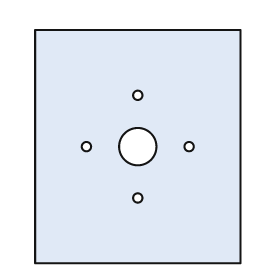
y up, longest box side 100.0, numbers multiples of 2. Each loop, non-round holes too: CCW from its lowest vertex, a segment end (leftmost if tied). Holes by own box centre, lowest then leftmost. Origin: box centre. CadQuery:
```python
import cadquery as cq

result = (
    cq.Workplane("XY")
    .moveTo(-44.0, -50.0)
    .lineTo(44.0, -50.0)
    .lineTo(44.0, 50.0)
    .lineTo(-44.0, 50.0)
    .close()
    .moveTo(0.0, -22.0)
    .circle(2.0)
    .moveTo(-22.0, 0.0)
    .circle(2.0)
    .moveTo(0.0, 0.0)
    .circle(8.0)
    .moveTo(22.0, 0.0)
    .circle(2.0)
    .moveTo(0.0, 22.0)
    .circle(2.0)
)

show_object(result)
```